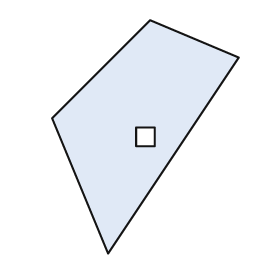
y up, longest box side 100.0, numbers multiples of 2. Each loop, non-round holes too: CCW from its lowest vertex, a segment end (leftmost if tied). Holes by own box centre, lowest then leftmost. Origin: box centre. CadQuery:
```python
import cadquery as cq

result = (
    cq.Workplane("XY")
    .moveTo(-16.0, -50.0)
    .lineTo(40.0, 34.0)
    .lineTo(2.0, 50.0)
    .lineTo(-40.0, 8.0)
    .close()
    .moveTo(-4.0, -4.0)
    .lineTo(4.0, -4.0)
    .lineTo(4.0, 4.0)
    .lineTo(-4.0, 4.0)
    .close()
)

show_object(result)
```